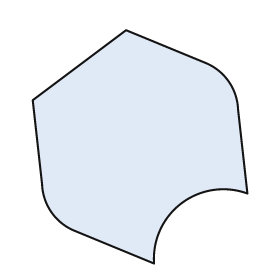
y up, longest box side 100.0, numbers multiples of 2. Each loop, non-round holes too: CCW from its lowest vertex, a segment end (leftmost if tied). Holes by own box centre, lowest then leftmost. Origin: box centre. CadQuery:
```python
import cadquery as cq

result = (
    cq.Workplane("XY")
    .moveTo(6.0, -50.0)
    .threePointArc((18.0, -24.0), (46.0, -20.0))
    .lineTo(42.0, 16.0)
    .threePointArc((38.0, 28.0), (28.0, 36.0))
    .lineTo(-6.0, 50.0)
    .lineTo(-46.0, 20.0)
    .lineTo(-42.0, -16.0)
    .threePointArc((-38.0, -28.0), (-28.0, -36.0))
    .close()
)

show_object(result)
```